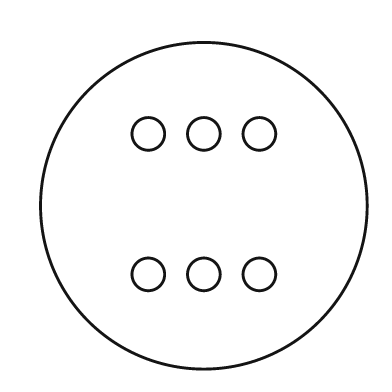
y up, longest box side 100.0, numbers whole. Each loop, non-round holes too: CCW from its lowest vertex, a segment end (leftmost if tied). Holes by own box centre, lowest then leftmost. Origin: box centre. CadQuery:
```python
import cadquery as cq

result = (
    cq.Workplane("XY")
    .moveTo(0.0, 0.0)
    .circle(50.0)
    .moveTo(-17.0, -21.0)
    .circle(5.0)
    .moveTo(0.0, -21.0)
    .circle(5.0)
    .moveTo(17.0, -21.0)
    .circle(5.0)
    .moveTo(-17.0, 22.0)
    .circle(5.0)
    .moveTo(0.0, 22.0)
    .circle(5.0)
    .moveTo(17.0, 22.0)
    .circle(5.0)
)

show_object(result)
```